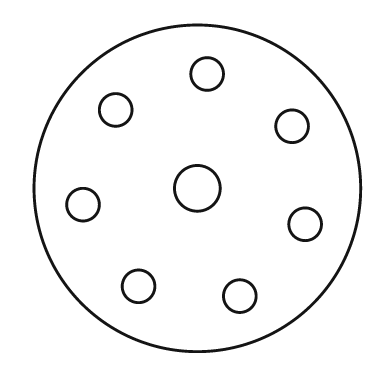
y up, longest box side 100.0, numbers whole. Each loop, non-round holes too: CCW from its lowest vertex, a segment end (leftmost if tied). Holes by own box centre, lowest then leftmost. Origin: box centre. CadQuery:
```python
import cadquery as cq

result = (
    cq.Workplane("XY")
    .moveTo(0.0, 0.0)
    .circle(50.0)
    .moveTo(13.0, -33.0)
    .circle(5.0)
    .moveTo(-18.0, -30.0)
    .circle(5.0)
    .moveTo(33.0, -11.0)
    .circle(5.0)
    .moveTo(-35.0, -5.0)
    .circle(5.0)
    .moveTo(0.0, 0.0)
    .circle(7.0)
    .moveTo(29.0, 19.0)
    .circle(5.0)
    .moveTo(-25.0, 24.0)
    .circle(5.0)
    .moveTo(3.0, 35.0)
    .circle(5.0)
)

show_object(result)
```